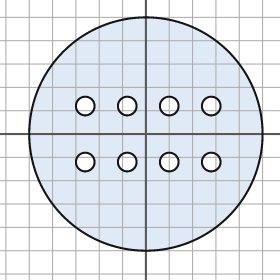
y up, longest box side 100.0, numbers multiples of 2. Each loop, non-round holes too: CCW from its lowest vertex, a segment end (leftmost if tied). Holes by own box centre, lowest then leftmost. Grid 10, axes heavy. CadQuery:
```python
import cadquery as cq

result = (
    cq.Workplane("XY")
    .moveTo(0.0, 0.0)
    .circle(50.0)
    .moveTo(-26.0, -12.0)
    .circle(4.0)
    .moveTo(-8.0, -12.0)
    .circle(4.0)
    .moveTo(10.0, -12.0)
    .circle(4.0)
    .moveTo(28.0, -12.0)
    .circle(4.0)
    .moveTo(-26.0, 12.0)
    .circle(4.0)
    .moveTo(-8.0, 12.0)
    .circle(4.0)
    .moveTo(10.0, 12.0)
    .circle(4.0)
    .moveTo(28.0, 12.0)
    .circle(4.0)
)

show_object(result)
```